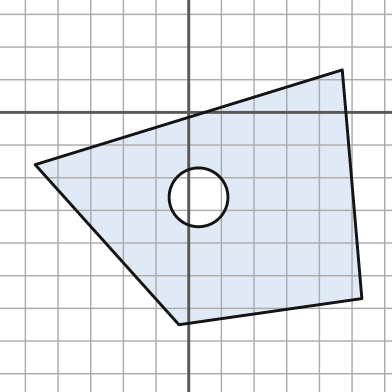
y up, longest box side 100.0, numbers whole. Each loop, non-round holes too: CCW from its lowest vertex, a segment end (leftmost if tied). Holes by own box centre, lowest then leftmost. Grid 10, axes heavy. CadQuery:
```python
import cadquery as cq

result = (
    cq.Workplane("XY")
    .moveTo(-3.0, -65.0)
    .lineTo(53.0, -57.0)
    .lineTo(47.0, 13.0)
    .lineTo(-47.0, -16.0)
    .close()
    .moveTo(3.0, -26.0)
    .circle(9.0)
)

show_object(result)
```